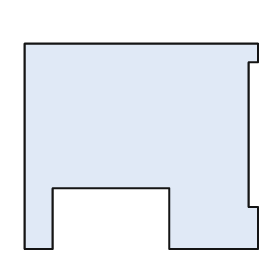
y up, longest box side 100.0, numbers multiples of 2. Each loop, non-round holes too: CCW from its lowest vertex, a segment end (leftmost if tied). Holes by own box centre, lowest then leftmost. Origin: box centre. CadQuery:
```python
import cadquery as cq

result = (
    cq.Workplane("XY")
    .moveTo(-50.0, -44.0)
    .lineTo(-38.0, -44.0)
    .lineTo(-38.0, -18.0)
    .lineTo(12.0, -18.0)
    .lineTo(12.0, -44.0)
    .lineTo(50.0, -44.0)
    .lineTo(50.0, -26.0)
    .lineTo(46.0, -26.0)
    .lineTo(46.0, 36.0)
    .lineTo(50.0, 36.0)
    .lineTo(50.0, 44.0)
    .lineTo(-50.0, 44.0)
    .close()
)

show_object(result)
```